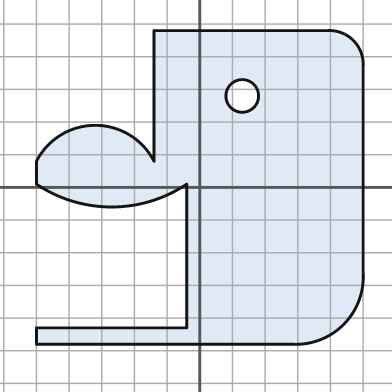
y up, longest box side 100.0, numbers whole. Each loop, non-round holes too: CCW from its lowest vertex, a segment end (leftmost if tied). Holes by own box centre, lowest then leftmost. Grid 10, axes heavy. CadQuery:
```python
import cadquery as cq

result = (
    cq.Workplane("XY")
    .moveTo(-50.0, -48.0)
    .lineTo(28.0, -48.0)
    .threePointArc((44.0, -42.0), (50.0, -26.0))
    .lineTo(50.0, 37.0)
    .threePointArc((47.0, 45.0), (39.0, 48.0))
    .lineTo(-14.0, 48.0)
    .lineTo(-14.0, 8.0)
    .threePointArc((-32.0, 19.0), (-50.0, 8.0))
    .lineTo(-50.0, 1.0)
    .threePointArc((-27.0, -6.0), (-4.0, 1.0))
    .lineTo(-4.0, -43.0)
    .lineTo(-50.0, -43.0)
    .close()
    .moveTo(13.0, 28.0)
    .circle(5.0)
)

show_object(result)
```